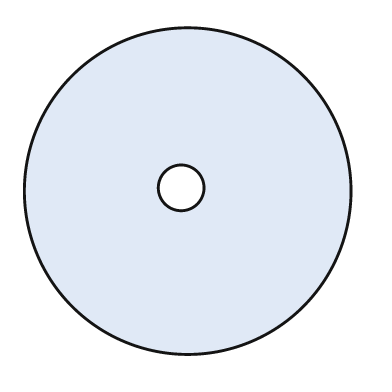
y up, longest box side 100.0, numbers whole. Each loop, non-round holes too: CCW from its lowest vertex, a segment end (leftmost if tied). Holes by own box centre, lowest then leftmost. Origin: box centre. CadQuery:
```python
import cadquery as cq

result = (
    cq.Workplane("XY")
    .moveTo(0.0, 0.0)
    .circle(50.0)
    .moveTo(-2.0, 1.0)
    .circle(7.0)
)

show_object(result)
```